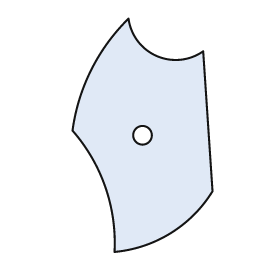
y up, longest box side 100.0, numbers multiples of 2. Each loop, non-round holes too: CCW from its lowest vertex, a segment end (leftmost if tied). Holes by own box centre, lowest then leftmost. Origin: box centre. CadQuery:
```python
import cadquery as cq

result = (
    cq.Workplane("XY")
    .moveTo(-12.0, -50.0)
    .threePointArc((12.0, -42.0), (30.0, -24.0))
    .lineTo(26.0, 36.0)
    .threePointArc((6.0, 34.0), (-6.0, 50.0))
    .threePointArc((-22.0, 28.0), (-30.0, 2.0))
    .threePointArc((-16.0, -22.0), (-12.0, -50.0))
    .close()
    .moveTo(0.0, 0.0)
    .circle(4.0)
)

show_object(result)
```